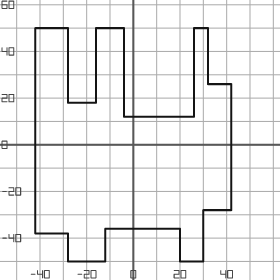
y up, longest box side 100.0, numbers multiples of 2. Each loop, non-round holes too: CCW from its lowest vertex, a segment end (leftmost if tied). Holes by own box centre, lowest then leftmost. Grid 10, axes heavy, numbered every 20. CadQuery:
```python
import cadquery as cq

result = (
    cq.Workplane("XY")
    .moveTo(-28.0, -50.0)
    .lineTo(-12.0, -50.0)
    .lineTo(-12.0, -36.0)
    .lineTo(20.0, -36.0)
    .lineTo(20.0, -50.0)
    .lineTo(30.0, -50.0)
    .lineTo(30.0, -28.0)
    .lineTo(42.0, -28.0)
    .lineTo(42.0, 26.0)
    .lineTo(32.0, 26.0)
    .lineTo(32.0, 50.0)
    .lineTo(26.0, 50.0)
    .lineTo(26.0, 12.0)
    .lineTo(-4.0, 12.0)
    .lineTo(-4.0, 50.0)
    .lineTo(-16.0, 50.0)
    .lineTo(-16.0, 18.0)
    .lineTo(-28.0, 18.0)
    .lineTo(-28.0, 50.0)
    .lineTo(-42.0, 50.0)
    .lineTo(-42.0, -38.0)
    .lineTo(-28.0, -38.0)
    .close()
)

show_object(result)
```